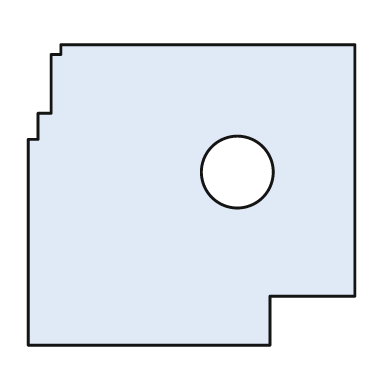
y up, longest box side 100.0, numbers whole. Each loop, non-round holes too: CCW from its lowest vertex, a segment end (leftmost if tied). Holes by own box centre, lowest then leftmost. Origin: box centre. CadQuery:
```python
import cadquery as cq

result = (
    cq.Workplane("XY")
    .moveTo(-50.0, -46.0)
    .lineTo(24.0, -46.0)
    .lineTo(24.0, -31.0)
    .lineTo(50.0, -31.0)
    .lineTo(50.0, 46.0)
    .lineTo(-40.0, 46.0)
    .lineTo(-40.0, 43.0)
    .lineTo(-43.0, 43.0)
    .lineTo(-43.0, 25.0)
    .lineTo(-47.0, 25.0)
    .lineTo(-47.0, 17.0)
    .lineTo(-50.0, 17.0)
    .close()
    .moveTo(14.0, 7.0)
    .circle(11.0)
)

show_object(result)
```